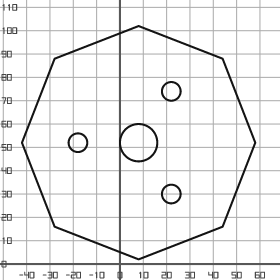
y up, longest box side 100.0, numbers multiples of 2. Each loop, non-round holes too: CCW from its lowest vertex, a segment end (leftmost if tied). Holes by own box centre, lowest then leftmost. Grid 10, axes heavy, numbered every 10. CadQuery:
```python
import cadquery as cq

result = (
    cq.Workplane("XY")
    .moveTo(8.0, 2.0)
    .lineTo(44.0, 16.0)
    .lineTo(58.0, 52.0)
    .lineTo(44.0, 88.0)
    .lineTo(8.0, 102.0)
    .lineTo(-28.0, 88.0)
    .lineTo(-42.0, 52.0)
    .lineTo(-28.0, 16.0)
    .close()
    .moveTo(22.0, 30.0)
    .circle(4.0)
    .moveTo(-18.0, 52.0)
    .circle(4.0)
    .moveTo(8.0, 52.0)
    .circle(8.0)
    .moveTo(22.0, 74.0)
    .circle(4.0)
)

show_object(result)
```